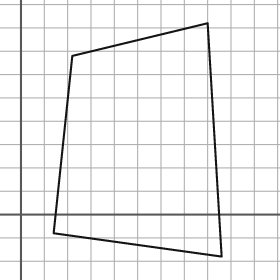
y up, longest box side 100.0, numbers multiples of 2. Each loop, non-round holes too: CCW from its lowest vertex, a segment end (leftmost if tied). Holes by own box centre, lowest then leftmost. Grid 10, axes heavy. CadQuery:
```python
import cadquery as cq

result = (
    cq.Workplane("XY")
    .moveTo(86.0, -18.0)
    .lineTo(80.0, 82.0)
    .lineTo(22.0, 68.0)
    .lineTo(14.0, -8.0)
    .close()
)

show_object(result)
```